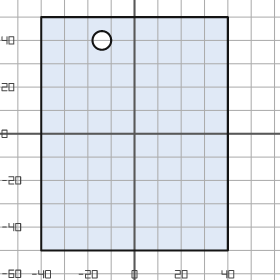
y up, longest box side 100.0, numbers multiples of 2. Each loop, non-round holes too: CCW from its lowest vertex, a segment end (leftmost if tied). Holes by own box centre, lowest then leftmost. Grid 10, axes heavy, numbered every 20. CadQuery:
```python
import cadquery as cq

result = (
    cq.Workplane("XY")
    .moveTo(-40.0, -50.0)
    .lineTo(40.0, -50.0)
    .lineTo(40.0, 50.0)
    .lineTo(-40.0, 50.0)
    .close()
    .moveTo(-14.0, 40.0)
    .circle(4.0)
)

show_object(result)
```